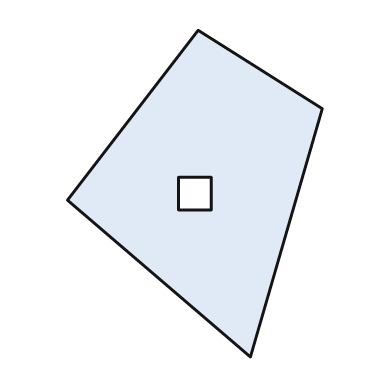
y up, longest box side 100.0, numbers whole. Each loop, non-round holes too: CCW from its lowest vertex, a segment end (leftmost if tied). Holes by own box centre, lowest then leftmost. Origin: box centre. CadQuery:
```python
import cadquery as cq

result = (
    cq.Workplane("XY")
    .moveTo(17.0, -50.0)
    .lineTo(39.0, 26.0)
    .lineTo(1.0, 50.0)
    .lineTo(-39.0, -2.0)
    .close()
    .moveTo(-5.0, -5.0)
    .lineTo(5.0, -5.0)
    .lineTo(5.0, 5.0)
    .lineTo(-5.0, 5.0)
    .close()
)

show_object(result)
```